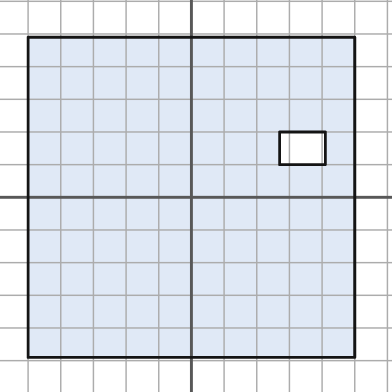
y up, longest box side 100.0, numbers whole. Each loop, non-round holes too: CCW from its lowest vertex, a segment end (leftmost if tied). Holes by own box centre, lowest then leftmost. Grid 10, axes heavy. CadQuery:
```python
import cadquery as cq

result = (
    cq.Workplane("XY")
    .moveTo(-50.0, -49.0)
    .lineTo(50.0, -49.0)
    .lineTo(50.0, 49.0)
    .lineTo(-50.0, 49.0)
    .close()
    .moveTo(27.0, 10.0)
    .lineTo(41.0, 10.0)
    .lineTo(41.0, 20.0)
    .lineTo(27.0, 20.0)
    .close()
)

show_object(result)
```